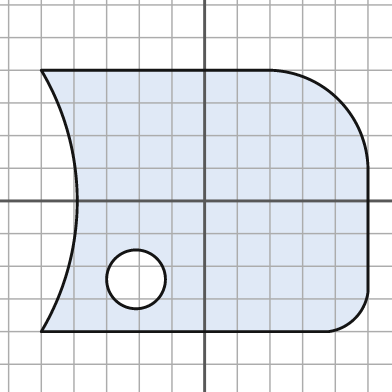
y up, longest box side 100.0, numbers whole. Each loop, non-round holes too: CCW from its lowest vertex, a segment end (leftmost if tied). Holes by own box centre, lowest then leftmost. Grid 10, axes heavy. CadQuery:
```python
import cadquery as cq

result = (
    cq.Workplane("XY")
    .moveTo(-50.0, -40.0)
    .lineTo(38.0, -40.0)
    .threePointArc((46.0, -36.0), (50.0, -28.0))
    .lineTo(50.0, 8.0)
    .threePointArc((41.0, 31.0), (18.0, 40.0))
    .lineTo(-50.0, 40.0)
    .threePointArc((-39.0, 0.0), (-50.0, -40.0))
    .close()
    .moveTo(-21.0, -24.0)
    .circle(9.0)
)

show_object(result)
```